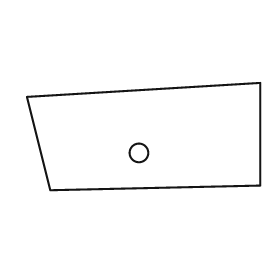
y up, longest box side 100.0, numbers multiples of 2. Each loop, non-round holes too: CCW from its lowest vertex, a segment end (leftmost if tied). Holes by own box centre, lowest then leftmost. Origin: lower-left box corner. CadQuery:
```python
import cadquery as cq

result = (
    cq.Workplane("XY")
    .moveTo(10.0, 0.0)
    .lineTo(100.0, 2.0)
    .lineTo(100.0, 46.0)
    .lineTo(0.0, 40.0)
    .close()
    .moveTo(48.0, 16.0)
    .circle(4.0)
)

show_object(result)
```